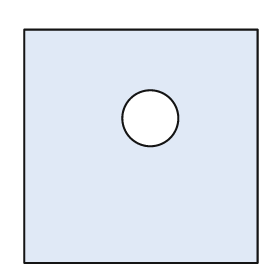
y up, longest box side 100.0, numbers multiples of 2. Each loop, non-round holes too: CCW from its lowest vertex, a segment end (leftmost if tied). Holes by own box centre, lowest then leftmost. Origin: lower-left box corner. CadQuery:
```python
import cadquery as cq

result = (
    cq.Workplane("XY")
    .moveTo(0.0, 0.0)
    .lineTo(100.0, 0.0)
    .lineTo(100.0, 100.0)
    .lineTo(0.0, 100.0)
    .close()
    .moveTo(54.0, 62.0)
    .circle(12.0)
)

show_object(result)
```